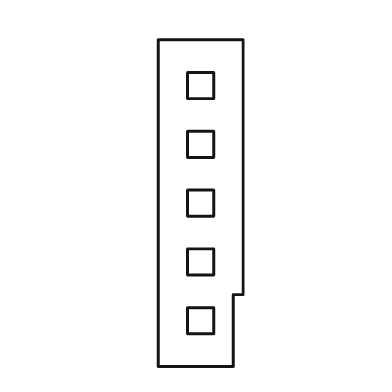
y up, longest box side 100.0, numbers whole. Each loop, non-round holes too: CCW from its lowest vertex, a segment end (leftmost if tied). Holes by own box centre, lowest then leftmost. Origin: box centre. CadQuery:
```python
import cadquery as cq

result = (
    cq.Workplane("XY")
    .moveTo(-13.0, -50.0)
    .lineTo(10.0, -50.0)
    .lineTo(10.0, -28.0)
    .lineTo(13.0, -28.0)
    .lineTo(13.0, 50.0)
    .lineTo(-13.0, 50.0)
    .close()
    .moveTo(-4.0, -40.0)
    .lineTo(4.0, -40.0)
    .lineTo(4.0, -32.0)
    .lineTo(-4.0, -32.0)
    .close()
    .moveTo(-4.0, -22.0)
    .lineTo(4.0, -22.0)
    .lineTo(4.0, -14.0)
    .lineTo(-4.0, -14.0)
    .close()
    .moveTo(-4.0, -4.0)
    .lineTo(4.0, -4.0)
    .lineTo(4.0, 4.0)
    .lineTo(-4.0, 4.0)
    .close()
    .moveTo(-4.0, 14.0)
    .lineTo(4.0, 14.0)
    .lineTo(4.0, 22.0)
    .lineTo(-4.0, 22.0)
    .close()
    .moveTo(-4.0, 32.0)
    .lineTo(4.0, 32.0)
    .lineTo(4.0, 40.0)
    .lineTo(-4.0, 40.0)
    .close()
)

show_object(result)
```